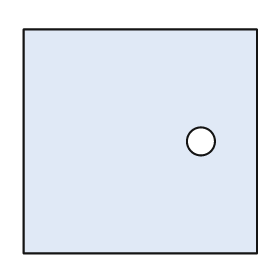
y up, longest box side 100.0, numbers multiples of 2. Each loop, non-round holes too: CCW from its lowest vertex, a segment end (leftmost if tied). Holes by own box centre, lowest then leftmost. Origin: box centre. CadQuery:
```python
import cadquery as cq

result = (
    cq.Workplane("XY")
    .moveTo(-50.0, -48.0)
    .lineTo(50.0, -48.0)
    .lineTo(50.0, 48.0)
    .lineTo(-50.0, 48.0)
    .close()
    .moveTo(26.0, 0.0)
    .circle(6.0)
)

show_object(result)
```